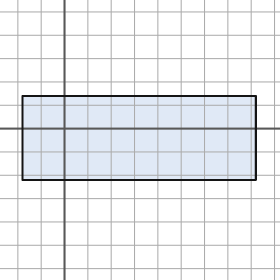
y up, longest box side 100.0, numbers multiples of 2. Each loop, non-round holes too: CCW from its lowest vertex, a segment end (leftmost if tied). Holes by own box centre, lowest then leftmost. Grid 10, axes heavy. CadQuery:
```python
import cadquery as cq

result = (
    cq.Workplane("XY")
    .moveTo(-18.0, -22.0)
    .lineTo(82.0, -22.0)
    .lineTo(82.0, 14.0)
    .lineTo(-18.0, 14.0)
    .close()
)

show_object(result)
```